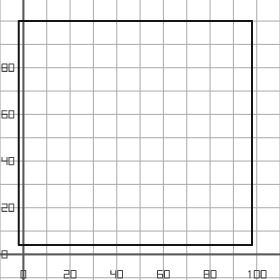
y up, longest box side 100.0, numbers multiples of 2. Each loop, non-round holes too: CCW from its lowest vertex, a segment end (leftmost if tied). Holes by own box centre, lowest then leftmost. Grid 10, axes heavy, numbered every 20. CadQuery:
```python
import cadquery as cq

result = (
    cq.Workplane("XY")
    .moveTo(-2.0, 4.0)
    .lineTo(98.0, 4.0)
    .lineTo(98.0, 100.0)
    .lineTo(-2.0, 100.0)
    .close()
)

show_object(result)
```